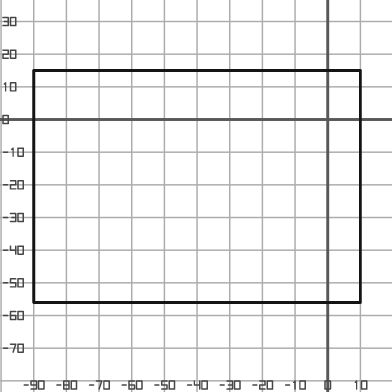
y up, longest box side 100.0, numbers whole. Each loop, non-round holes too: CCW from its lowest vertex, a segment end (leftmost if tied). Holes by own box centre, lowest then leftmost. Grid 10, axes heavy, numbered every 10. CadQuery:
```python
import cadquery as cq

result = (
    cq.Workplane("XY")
    .moveTo(-90.0, -56.0)
    .lineTo(10.0, -56.0)
    .lineTo(10.0, 15.0)
    .lineTo(-90.0, 15.0)
    .close()
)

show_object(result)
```